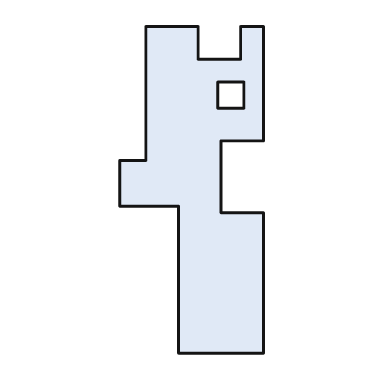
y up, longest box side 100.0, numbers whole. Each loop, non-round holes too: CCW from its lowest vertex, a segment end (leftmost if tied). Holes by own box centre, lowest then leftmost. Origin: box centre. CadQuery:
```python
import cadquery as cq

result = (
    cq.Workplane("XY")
    .moveTo(-4.0, -50.0)
    .lineTo(22.0, -50.0)
    .lineTo(22.0, -7.0)
    .lineTo(9.0, -7.0)
    .lineTo(9.0, 15.0)
    .lineTo(22.0, 15.0)
    .lineTo(22.0, 50.0)
    .lineTo(15.0, 50.0)
    .lineTo(15.0, 40.0)
    .lineTo(2.0, 40.0)
    .lineTo(2.0, 50.0)
    .lineTo(-14.0, 50.0)
    .lineTo(-14.0, 9.0)
    .lineTo(-22.0, 9.0)
    .lineTo(-22.0, -5.0)
    .lineTo(-4.0, -5.0)
    .close()
    .moveTo(8.0, 25.0)
    .lineTo(16.0, 25.0)
    .lineTo(16.0, 33.0)
    .lineTo(8.0, 33.0)
    .close()
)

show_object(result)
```